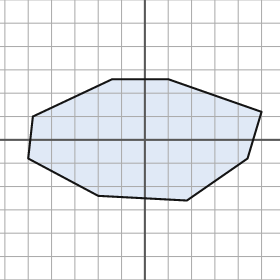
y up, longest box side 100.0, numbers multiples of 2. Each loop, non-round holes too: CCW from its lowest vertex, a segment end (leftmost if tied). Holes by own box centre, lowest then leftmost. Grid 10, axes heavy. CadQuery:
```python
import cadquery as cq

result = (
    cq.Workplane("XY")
    .moveTo(18.0, -26.0)
    .lineTo(44.0, -8.0)
    .lineTo(50.0, 12.0)
    .lineTo(10.0, 26.0)
    .lineTo(-14.0, 26.0)
    .lineTo(-48.0, 10.0)
    .lineTo(-50.0, -8.0)
    .lineTo(-20.0, -24.0)
    .close()
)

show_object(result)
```